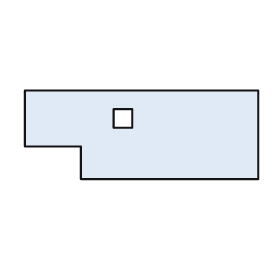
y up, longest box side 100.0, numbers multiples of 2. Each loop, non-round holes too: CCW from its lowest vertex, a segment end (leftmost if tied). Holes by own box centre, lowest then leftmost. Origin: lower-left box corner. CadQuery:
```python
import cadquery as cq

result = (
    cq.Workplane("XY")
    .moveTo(24.0, 0.0)
    .lineTo(100.0, 0.0)
    .lineTo(100.0, 38.0)
    .lineTo(0.0, 38.0)
    .lineTo(0.0, 14.0)
    .lineTo(24.0, 14.0)
    .close()
    .moveTo(38.0, 22.0)
    .lineTo(46.0, 22.0)
    .lineTo(46.0, 30.0)
    .lineTo(38.0, 30.0)
    .close()
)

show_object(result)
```